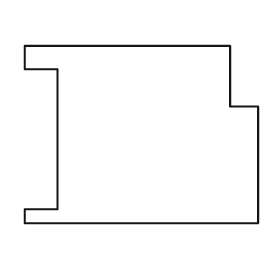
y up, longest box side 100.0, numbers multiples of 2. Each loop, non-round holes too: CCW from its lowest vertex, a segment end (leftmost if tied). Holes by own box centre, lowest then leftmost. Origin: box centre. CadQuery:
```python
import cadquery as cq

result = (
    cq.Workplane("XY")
    .moveTo(-50.0, -38.0)
    .lineTo(50.0, -38.0)
    .lineTo(50.0, 12.0)
    .lineTo(38.0, 12.0)
    .lineTo(38.0, 38.0)
    .lineTo(-50.0, 38.0)
    .lineTo(-50.0, 28.0)
    .lineTo(-36.0, 28.0)
    .lineTo(-36.0, -32.0)
    .lineTo(-50.0, -32.0)
    .close()
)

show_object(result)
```